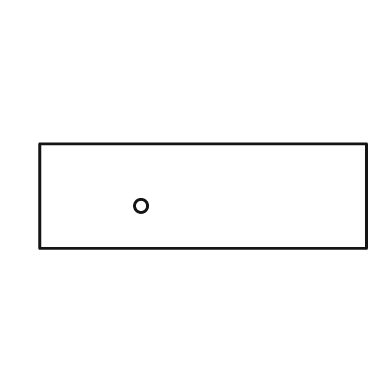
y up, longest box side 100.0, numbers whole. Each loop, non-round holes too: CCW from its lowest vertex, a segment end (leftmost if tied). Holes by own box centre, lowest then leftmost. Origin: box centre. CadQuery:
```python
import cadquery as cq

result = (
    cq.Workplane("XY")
    .moveTo(-50.0, -16.0)
    .lineTo(50.0, -16.0)
    .lineTo(50.0, 16.0)
    .lineTo(-50.0, 16.0)
    .close()
    .moveTo(-19.0, -3.0)
    .circle(2.0)
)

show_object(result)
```